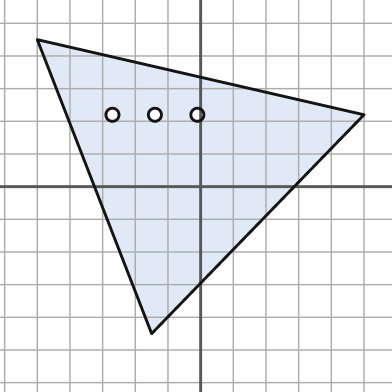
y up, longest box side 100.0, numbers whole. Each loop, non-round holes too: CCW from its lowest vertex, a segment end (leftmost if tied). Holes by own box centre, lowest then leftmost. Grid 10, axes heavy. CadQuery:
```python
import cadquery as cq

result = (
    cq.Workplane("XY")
    .moveTo(-15.0, -45.0)
    .lineTo(50.0, 22.0)
    .lineTo(-50.0, 45.0)
    .close()
    .moveTo(-27.0, 22.0)
    .circle(2.0)
    .moveTo(-14.0, 22.0)
    .circle(2.0)
    .moveTo(-1.0, 22.0)
    .circle(2.0)
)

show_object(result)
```